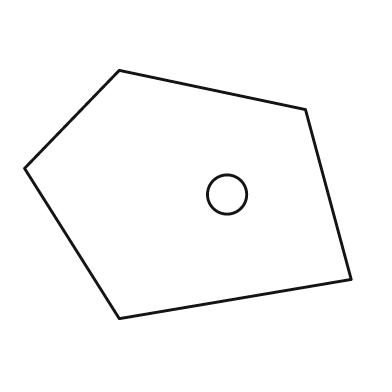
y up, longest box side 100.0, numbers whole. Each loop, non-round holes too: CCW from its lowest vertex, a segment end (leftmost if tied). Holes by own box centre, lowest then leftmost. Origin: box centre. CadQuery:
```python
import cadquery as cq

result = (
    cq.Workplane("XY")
    .moveTo(-21.0, -38.0)
    .lineTo(50.0, -26.0)
    .lineTo(36.0, 26.0)
    .lineTo(-21.0, 38.0)
    .lineTo(-50.0, 8.0)
    .close()
    .moveTo(12.0, 0.0)
    .circle(6.0)
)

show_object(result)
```